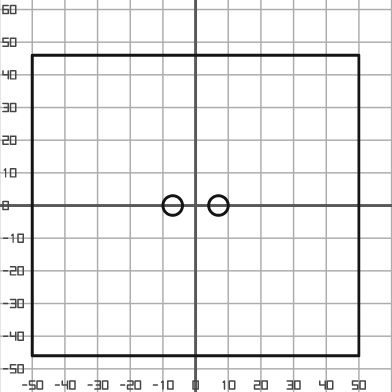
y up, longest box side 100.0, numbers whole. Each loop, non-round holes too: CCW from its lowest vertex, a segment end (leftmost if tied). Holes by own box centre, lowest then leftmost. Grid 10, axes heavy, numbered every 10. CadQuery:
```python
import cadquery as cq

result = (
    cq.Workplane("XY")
    .moveTo(-50.0, -46.0)
    .lineTo(50.0, -46.0)
    .lineTo(50.0, 46.0)
    .lineTo(-50.0, 46.0)
    .close()
    .moveTo(-7.0, 0.0)
    .circle(3.0)
    .moveTo(7.0, 0.0)
    .circle(3.0)
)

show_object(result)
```